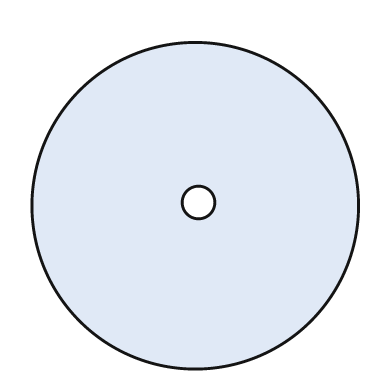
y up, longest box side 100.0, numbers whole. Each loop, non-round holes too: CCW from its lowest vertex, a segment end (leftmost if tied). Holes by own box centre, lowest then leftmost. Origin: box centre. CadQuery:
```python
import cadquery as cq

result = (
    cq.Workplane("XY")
    .moveTo(0.0, 0.0)
    .circle(50.0)
    .moveTo(1.0, 1.0)
    .circle(5.0)
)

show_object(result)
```